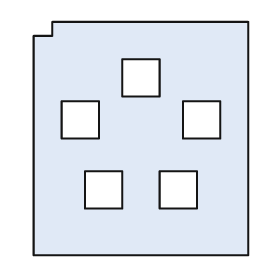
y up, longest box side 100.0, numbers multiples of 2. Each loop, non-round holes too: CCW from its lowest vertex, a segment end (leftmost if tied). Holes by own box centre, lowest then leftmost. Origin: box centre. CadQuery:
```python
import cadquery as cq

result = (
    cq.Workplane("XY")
    .moveTo(-46.0, -50.0)
    .lineTo(46.0, -50.0)
    .lineTo(46.0, 50.0)
    .lineTo(-38.0, 50.0)
    .lineTo(-38.0, 44.0)
    .lineTo(-46.0, 44.0)
    .close()
    .moveTo(-24.0, -30.0)
    .lineTo(-8.0, -30.0)
    .lineTo(-8.0, -14.0)
    .lineTo(-24.0, -14.0)
    .close()
    .moveTo(8.0, -30.0)
    .lineTo(24.0, -30.0)
    .lineTo(24.0, -14.0)
    .lineTo(8.0, -14.0)
    .close()
    .moveTo(-34.0, 0.0)
    .lineTo(-18.0, 0.0)
    .lineTo(-18.0, 16.0)
    .lineTo(-34.0, 16.0)
    .close()
    .moveTo(18.0, 0.0)
    .lineTo(34.0, 0.0)
    .lineTo(34.0, 16.0)
    .lineTo(18.0, 16.0)
    .close()
    .moveTo(-8.0, 18.0)
    .lineTo(8.0, 18.0)
    .lineTo(8.0, 34.0)
    .lineTo(-8.0, 34.0)
    .close()
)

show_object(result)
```